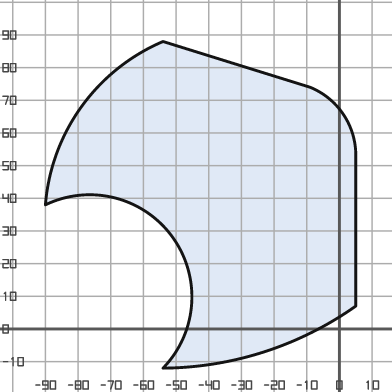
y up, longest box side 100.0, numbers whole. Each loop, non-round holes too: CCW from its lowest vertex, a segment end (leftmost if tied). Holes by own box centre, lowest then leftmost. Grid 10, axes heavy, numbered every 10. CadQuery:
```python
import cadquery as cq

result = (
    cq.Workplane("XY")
    .moveTo(-54.0, -12.0)
    .threePointArc((-23.0, -7.0), (5.0, 7.0))
    .lineTo(5.0, 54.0)
    .threePointArc((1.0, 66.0), (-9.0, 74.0))
    .lineTo(-54.0, 88.0)
    .threePointArc((-79.0, 68.0), (-90.0, 38.0))
    .threePointArc((-51.0, 28.0), (-54.0, -12.0))
    .close()
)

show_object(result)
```